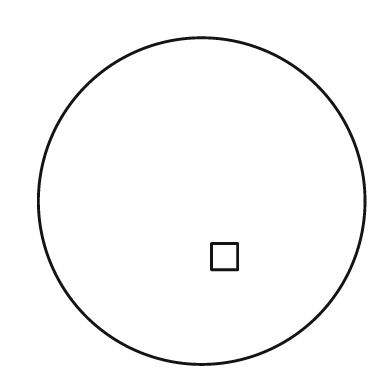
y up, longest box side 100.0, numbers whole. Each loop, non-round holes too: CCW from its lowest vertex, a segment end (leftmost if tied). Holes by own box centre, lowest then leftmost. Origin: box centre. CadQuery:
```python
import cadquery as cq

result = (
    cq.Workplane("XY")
    .moveTo(0.0, 0.0)
    .circle(50.0)
    .moveTo(3.0, -21.0)
    .lineTo(11.0, -21.0)
    .lineTo(11.0, -13.0)
    .lineTo(3.0, -13.0)
    .close()
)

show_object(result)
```